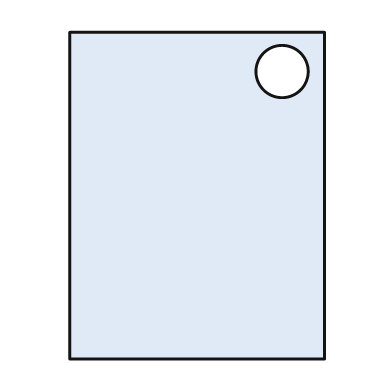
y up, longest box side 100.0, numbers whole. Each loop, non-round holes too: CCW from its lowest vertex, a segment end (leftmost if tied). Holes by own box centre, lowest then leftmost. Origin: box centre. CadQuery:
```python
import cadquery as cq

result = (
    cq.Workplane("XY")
    .moveTo(-39.0, -50.0)
    .lineTo(39.0, -50.0)
    .lineTo(39.0, 50.0)
    .lineTo(-39.0, 50.0)
    .close()
    .moveTo(26.0, 38.0)
    .circle(8.0)
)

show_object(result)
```